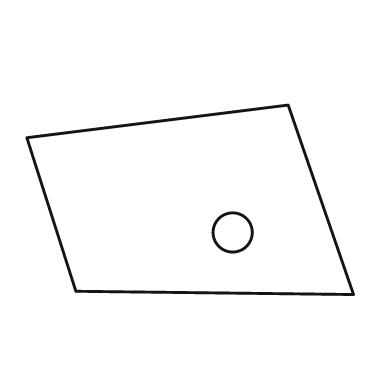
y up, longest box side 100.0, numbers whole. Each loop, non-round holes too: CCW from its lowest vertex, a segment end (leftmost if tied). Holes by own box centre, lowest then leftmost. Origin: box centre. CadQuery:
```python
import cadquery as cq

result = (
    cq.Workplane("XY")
    .moveTo(50.0, -29.0)
    .lineTo(30.0, 29.0)
    .lineTo(-50.0, 19.0)
    .lineTo(-35.0, -28.0)
    .close()
    .moveTo(13.0, -10.0)
    .circle(6.0)
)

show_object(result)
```